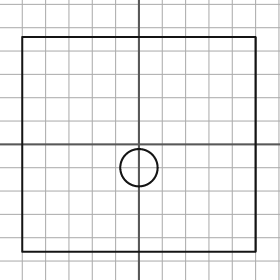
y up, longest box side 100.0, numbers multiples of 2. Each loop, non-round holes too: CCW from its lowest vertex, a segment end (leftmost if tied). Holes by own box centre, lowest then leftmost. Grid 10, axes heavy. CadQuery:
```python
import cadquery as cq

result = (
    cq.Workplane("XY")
    .moveTo(-50.0, -46.0)
    .lineTo(50.0, -46.0)
    .lineTo(50.0, 46.0)
    .lineTo(-50.0, 46.0)
    .close()
    .moveTo(0.0, -10.0)
    .circle(8.0)
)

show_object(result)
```